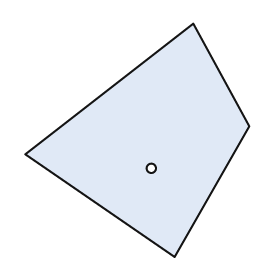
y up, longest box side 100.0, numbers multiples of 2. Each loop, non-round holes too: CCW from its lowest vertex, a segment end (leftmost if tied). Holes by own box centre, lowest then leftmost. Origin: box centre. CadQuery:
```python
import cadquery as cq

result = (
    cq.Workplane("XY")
    .moveTo(16.0, -50.0)
    .lineTo(48.0, 6.0)
    .lineTo(24.0, 50.0)
    .lineTo(-48.0, -6.0)
    .close()
    .moveTo(6.0, -12.0)
    .circle(2.0)
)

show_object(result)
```